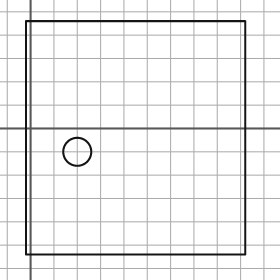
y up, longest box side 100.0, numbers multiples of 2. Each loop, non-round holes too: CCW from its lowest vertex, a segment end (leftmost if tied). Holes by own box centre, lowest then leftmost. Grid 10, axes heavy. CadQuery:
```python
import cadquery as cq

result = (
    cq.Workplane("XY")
    .moveTo(-2.0, -54.0)
    .lineTo(92.0, -54.0)
    .lineTo(92.0, 46.0)
    .lineTo(-2.0, 46.0)
    .close()
    .moveTo(20.0, -10.0)
    .circle(6.0)
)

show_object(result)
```